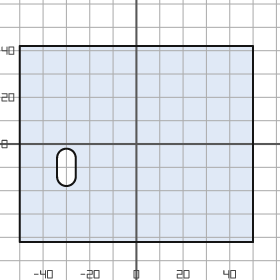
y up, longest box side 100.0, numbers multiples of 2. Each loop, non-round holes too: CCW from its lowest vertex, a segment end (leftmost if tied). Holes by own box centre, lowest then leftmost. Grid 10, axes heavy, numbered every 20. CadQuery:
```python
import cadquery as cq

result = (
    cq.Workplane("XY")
    .moveTo(-50.0, -42.0)
    .lineTo(50.0, -42.0)
    .lineTo(50.0, 42.0)
    .lineTo(-50.0, 42.0)
    .close()
    .moveTo(-34.0, -14.0)
    .threePointArc((-30.0, -18.0), (-26.0, -14.0))
    .lineTo(-26.0, -6.0)
    .threePointArc((-30.0, -2.0), (-34.0, -6.0))
    .close()
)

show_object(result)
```